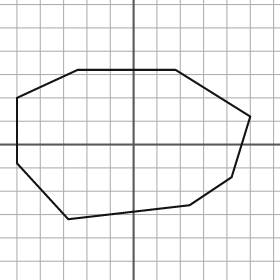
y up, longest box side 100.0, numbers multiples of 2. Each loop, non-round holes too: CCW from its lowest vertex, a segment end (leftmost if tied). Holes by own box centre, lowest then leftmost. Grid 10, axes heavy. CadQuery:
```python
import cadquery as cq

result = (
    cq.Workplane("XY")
    .moveTo(-28.0, -32.0)
    .lineTo(24.0, -26.0)
    .lineTo(42.0, -14.0)
    .lineTo(50.0, 12.0)
    .lineTo(18.0, 32.0)
    .lineTo(-24.0, 32.0)
    .lineTo(-50.0, 20.0)
    .lineTo(-50.0, -8.0)
    .close()
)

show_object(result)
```